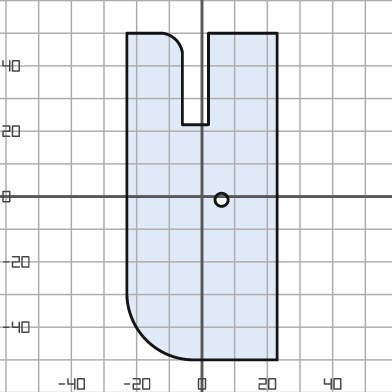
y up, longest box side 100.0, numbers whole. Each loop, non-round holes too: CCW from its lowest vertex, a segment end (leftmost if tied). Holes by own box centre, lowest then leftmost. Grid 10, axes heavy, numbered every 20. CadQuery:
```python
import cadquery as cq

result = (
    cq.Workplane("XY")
    .moveTo(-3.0, -50.0)
    .lineTo(23.0, -50.0)
    .lineTo(23.0, 50.0)
    .lineTo(2.0, 50.0)
    .lineTo(2.0, 22.0)
    .lineTo(-6.0, 22.0)
    .lineTo(-6.0, 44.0)
    .threePointArc((-8.0, 48.0), (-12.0, 50.0))
    .lineTo(-23.0, 50.0)
    .lineTo(-23.0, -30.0)
    .threePointArc((-17.0, -44.0), (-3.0, -50.0))
    .close()
    .moveTo(6.0, -1.0)
    .circle(2.0)
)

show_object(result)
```